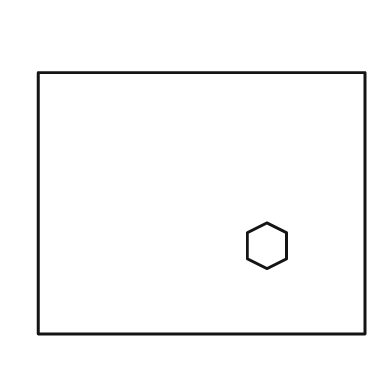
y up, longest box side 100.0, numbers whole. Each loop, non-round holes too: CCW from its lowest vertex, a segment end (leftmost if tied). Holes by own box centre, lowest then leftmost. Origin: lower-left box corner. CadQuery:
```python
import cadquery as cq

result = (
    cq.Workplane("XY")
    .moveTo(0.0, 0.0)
    .lineTo(100.0, 0.0)
    .lineTo(100.0, 80.0)
    .lineTo(0.0, 80.0)
    .close()
    .moveTo(70.0, 20.0)
    .lineTo(76.0, 23.0)
    .lineTo(76.0, 31.0)
    .lineTo(70.0, 34.0)
    .lineTo(64.0, 31.0)
    .lineTo(64.0, 23.0)
    .close()
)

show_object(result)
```